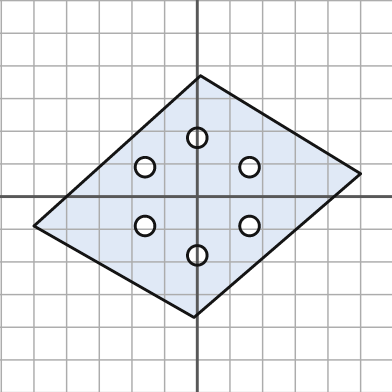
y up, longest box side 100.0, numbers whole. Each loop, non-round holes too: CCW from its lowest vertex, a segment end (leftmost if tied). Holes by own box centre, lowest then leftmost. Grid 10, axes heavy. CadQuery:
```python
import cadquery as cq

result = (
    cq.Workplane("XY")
    .moveTo(-1.0, -37.0)
    .lineTo(50.0, 7.0)
    .lineTo(1.0, 37.0)
    .lineTo(-50.0, -9.0)
    .close()
    .moveTo(0.0, -18.0)
    .circle(3.0)
    .moveTo(-16.0, -9.0)
    .circle(3.0)
    .moveTo(16.0, -9.0)
    .circle(3.0)
    .moveTo(-16.0, 9.0)
    .circle(3.0)
    .moveTo(16.0, 9.0)
    .circle(3.0)
    .moveTo(0.0, 18.0)
    .circle(3.0)
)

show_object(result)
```